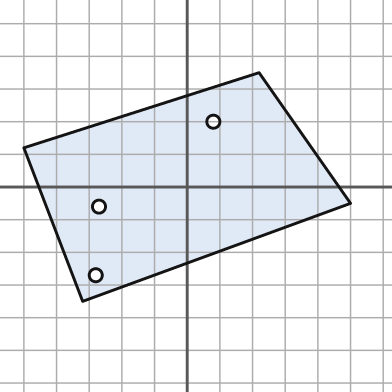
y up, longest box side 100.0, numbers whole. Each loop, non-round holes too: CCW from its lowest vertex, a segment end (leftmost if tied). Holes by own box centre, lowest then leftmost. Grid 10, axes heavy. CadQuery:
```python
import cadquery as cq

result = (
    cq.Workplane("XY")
    .moveTo(-32.0, -35.0)
    .lineTo(50.0, -5.0)
    .lineTo(22.0, 35.0)
    .lineTo(-50.0, 12.0)
    .close()
    .moveTo(-28.0, -27.0)
    .circle(2.0)
    .moveTo(-27.0, -6.0)
    .circle(2.0)
    .moveTo(8.0, 20.0)
    .circle(2.0)
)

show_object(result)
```